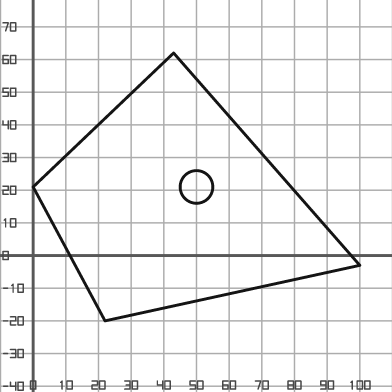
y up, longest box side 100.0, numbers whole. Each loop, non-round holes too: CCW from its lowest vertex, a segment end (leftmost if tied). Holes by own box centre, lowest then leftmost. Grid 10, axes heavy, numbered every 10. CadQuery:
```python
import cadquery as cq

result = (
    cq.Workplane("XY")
    .moveTo(22.0, -20.0)
    .lineTo(100.0, -3.0)
    .lineTo(43.0, 62.0)
    .lineTo(0.0, 21.0)
    .close()
    .moveTo(50.0, 21.0)
    .circle(5.0)
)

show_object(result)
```